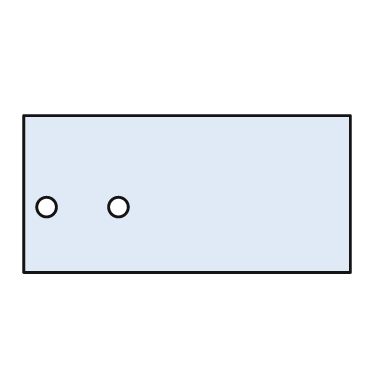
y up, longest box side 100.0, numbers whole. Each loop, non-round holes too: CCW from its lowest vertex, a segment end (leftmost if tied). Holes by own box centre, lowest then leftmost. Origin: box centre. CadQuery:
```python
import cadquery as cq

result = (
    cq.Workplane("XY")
    .moveTo(-50.0, -24.0)
    .lineTo(50.0, -24.0)
    .lineTo(50.0, 24.0)
    .lineTo(-50.0, 24.0)
    .close()
    .moveTo(-43.0, -4.0)
    .circle(3.0)
    .moveTo(-21.0, -4.0)
    .circle(3.0)
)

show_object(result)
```